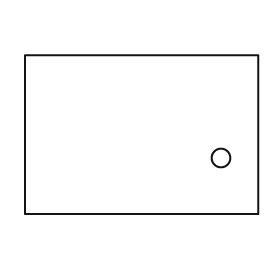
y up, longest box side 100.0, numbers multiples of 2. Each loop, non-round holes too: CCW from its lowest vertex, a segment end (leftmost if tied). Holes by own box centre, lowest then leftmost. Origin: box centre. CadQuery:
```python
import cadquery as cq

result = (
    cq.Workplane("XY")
    .moveTo(-50.0, -34.0)
    .lineTo(50.0, -34.0)
    .lineTo(50.0, 34.0)
    .lineTo(-50.0, 34.0)
    .close()
    .moveTo(34.0, -10.0)
    .circle(4.0)
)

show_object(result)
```